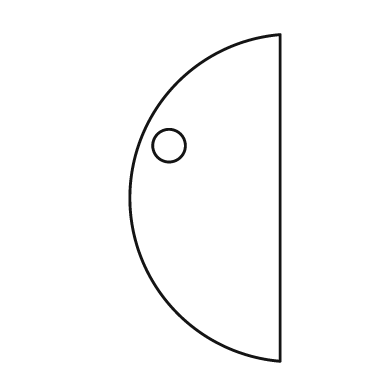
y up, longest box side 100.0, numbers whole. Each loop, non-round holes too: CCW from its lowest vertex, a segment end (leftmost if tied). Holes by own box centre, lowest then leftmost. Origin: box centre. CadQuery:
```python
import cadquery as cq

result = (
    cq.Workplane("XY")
    .moveTo(23.0, -50.0)
    .lineTo(23.0, 50.0)
    .threePointArc((-23.0, 0.0), (23.0, -50.0))
    .close()
    .moveTo(-11.0, 16.0)
    .circle(5.0)
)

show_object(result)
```